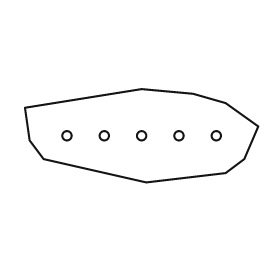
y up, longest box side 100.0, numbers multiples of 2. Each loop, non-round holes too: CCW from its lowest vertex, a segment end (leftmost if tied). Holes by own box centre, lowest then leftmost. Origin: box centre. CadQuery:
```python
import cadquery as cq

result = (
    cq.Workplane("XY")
    .moveTo(2.0, -20.0)
    .lineTo(36.0, -16.0)
    .lineTo(44.0, -10.0)
    .lineTo(50.0, 4.0)
    .lineTo(36.0, 14.0)
    .lineTo(22.0, 18.0)
    .lineTo(0.0, 20.0)
    .lineTo(-50.0, 12.0)
    .lineTo(-48.0, -2.0)
    .lineTo(-42.0, -10.0)
    .close()
    .moveTo(-32.0, 0.0)
    .circle(2.0)
    .moveTo(-16.0, 0.0)
    .circle(2.0)
    .moveTo(0.0, 0.0)
    .circle(2.0)
    .moveTo(16.0, 0.0)
    .circle(2.0)
    .moveTo(32.0, 0.0)
    .circle(2.0)
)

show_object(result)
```